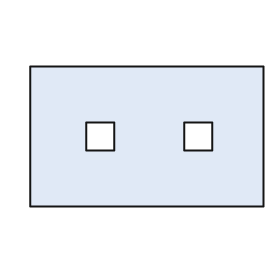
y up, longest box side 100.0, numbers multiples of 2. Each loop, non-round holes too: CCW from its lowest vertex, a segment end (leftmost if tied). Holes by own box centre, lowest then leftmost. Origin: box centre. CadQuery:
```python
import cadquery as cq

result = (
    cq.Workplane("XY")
    .moveTo(-50.0, -30.0)
    .lineTo(50.0, -30.0)
    .lineTo(50.0, 30.0)
    .lineTo(-50.0, 30.0)
    .close()
    .moveTo(-26.0, -6.0)
    .lineTo(-14.0, -6.0)
    .lineTo(-14.0, 6.0)
    .lineTo(-26.0, 6.0)
    .close()
    .moveTo(16.0, -6.0)
    .lineTo(28.0, -6.0)
    .lineTo(28.0, 6.0)
    .lineTo(16.0, 6.0)
    .close()
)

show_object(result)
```